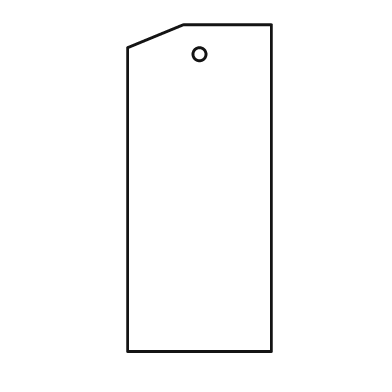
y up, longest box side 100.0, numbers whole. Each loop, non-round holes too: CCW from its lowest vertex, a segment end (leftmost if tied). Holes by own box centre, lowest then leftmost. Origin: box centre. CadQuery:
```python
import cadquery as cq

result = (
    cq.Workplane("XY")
    .moveTo(-22.0, -50.0)
    .lineTo(22.0, -50.0)
    .lineTo(22.0, 50.0)
    .lineTo(-5.0, 50.0)
    .lineTo(-22.0, 43.0)
    .close()
    .moveTo(0.0, 41.0)
    .circle(2.0)
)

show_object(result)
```